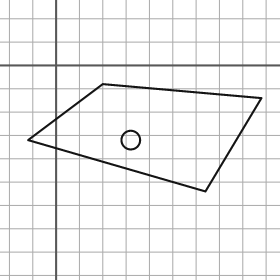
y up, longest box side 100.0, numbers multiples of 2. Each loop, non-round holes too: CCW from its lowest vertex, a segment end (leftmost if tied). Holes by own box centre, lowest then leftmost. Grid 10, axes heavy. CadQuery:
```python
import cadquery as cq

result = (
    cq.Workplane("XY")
    .moveTo(64.0, -54.0)
    .lineTo(88.0, -14.0)
    .lineTo(20.0, -8.0)
    .lineTo(-12.0, -32.0)
    .close()
    .moveTo(32.0, -32.0)
    .circle(4.0)
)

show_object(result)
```